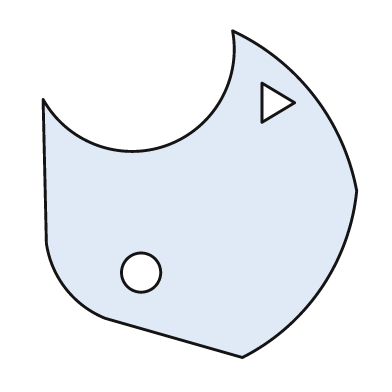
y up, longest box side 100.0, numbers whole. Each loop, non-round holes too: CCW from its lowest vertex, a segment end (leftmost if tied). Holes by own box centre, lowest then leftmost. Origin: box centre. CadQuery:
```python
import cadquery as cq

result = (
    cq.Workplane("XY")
    .moveTo(13.0, -50.0)
    .threePointArc((37.0, -29.0), (48.0, 1.0))
    .threePointArc((35.0, 30.0), (10.0, 50.0))
    .threePointArc((-10.0, 15.0), (-48.0, 29.0))
    .lineTo(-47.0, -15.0)
    .threePointArc((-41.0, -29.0), (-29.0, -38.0))
    .close()
    .moveTo(-18.0, -24.0)
    .circle(6.0)
    .moveTo(19.0, 22.0)
    .lineTo(29.0, 28.0)
    .lineTo(19.0, 34.0)
    .close()
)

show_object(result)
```